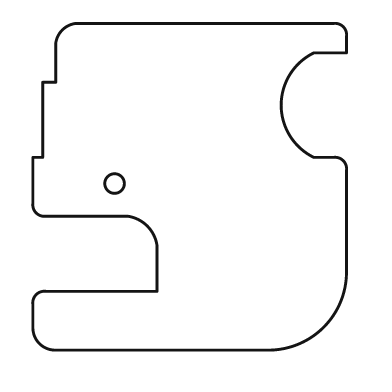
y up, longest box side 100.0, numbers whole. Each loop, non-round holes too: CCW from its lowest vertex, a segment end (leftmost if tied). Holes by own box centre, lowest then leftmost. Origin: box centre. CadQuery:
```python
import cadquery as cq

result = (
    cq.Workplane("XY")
    .moveTo(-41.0, -50.0)
    .lineTo(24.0, -50.0)
    .threePointArc((41.0, -43.0), (48.0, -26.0))
    .lineTo(48.0, 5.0)
    .threePointArc((47.0, 8.0), (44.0, 9.0))
    .lineTo(38.0, 9.0)
    .threePointArc((28.0, 25.0), (38.0, 41.0))
    .lineTo(48.0, 41.0)
    .lineTo(48.0, 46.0)
    .threePointArc((47.0, 49.0), (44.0, 50.0))
    .lineTo(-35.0, 50.0)
    .threePointArc((-39.0, 48.0), (-41.0, 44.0))
    .lineTo(-41.0, 32.0)
    .lineTo(-45.0, 32.0)
    .lineTo(-45.0, 9.0)
    .lineTo(-48.0, 9.0)
    .lineTo(-48.0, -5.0)
    .threePointArc((-47.0, -8.0), (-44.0, -9.0))
    .lineTo(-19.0, -9.0)
    .threePointArc((-13.0, -12.0), (-10.0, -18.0))
    .lineTo(-10.0, -32.0)
    .lineTo(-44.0, -32.0)
    .threePointArc((-47.0, -33.0), (-48.0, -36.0))
    .lineTo(-48.0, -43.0)
    .threePointArc((-46.0, -48.0), (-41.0, -50.0))
    .close()
    .moveTo(-23.0, 1.0)
    .circle(3.0)
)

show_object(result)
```